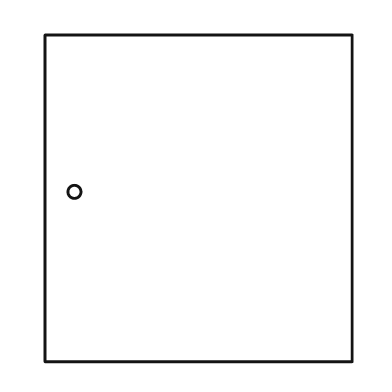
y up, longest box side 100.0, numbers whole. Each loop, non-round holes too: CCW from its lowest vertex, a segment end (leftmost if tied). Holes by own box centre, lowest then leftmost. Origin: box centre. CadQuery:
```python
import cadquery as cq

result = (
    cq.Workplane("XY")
    .moveTo(-47.0, -50.0)
    .lineTo(47.0, -50.0)
    .lineTo(47.0, 50.0)
    .lineTo(-47.0, 50.0)
    .close()
    .moveTo(-38.0, 2.0)
    .circle(2.0)
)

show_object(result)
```